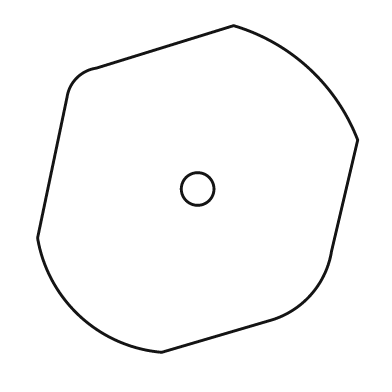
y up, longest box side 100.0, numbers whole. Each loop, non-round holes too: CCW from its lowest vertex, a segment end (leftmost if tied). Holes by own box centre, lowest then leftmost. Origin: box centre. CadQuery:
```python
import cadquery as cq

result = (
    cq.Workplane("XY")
    .moveTo(-11.0, -50.0)
    .lineTo(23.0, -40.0)
    .threePointArc((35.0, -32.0), (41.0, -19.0))
    .lineTo(49.0, 15.0)
    .threePointArc((34.0, 37.0), (11.0, 50.0))
    .lineTo(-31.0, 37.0)
    .threePointArc((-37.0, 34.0), (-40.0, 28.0))
    .lineTo(-49.0, -15.0)
    .threePointArc((-36.0, -39.0), (-11.0, -50.0))
    .close()
    .moveTo(0.0, 0.0)
    .circle(5.0)
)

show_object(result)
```